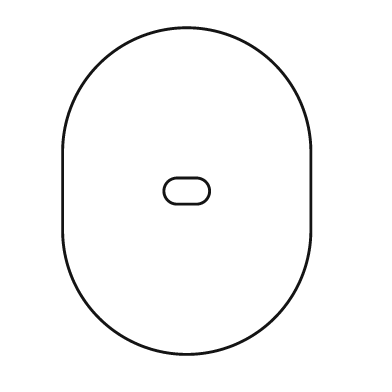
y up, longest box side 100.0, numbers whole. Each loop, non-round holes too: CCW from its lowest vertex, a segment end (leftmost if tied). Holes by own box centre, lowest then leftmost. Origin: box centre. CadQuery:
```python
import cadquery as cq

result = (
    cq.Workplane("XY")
    .moveTo(-38.0, -12.0)
    .threePointArc((0.0, -50.0), (38.0, -12.0))
    .lineTo(38.0, 12.0)
    .threePointArc((0.0, 50.0), (-38.0, 12.0))
    .close()
    .moveTo(-3.0, -4.0)
    .lineTo(3.0, -4.0)
    .threePointArc((7.0, 0.0), (3.0, 4.0))
    .lineTo(-3.0, 4.0)
    .threePointArc((-7.0, 0.0), (-3.0, -4.0))
    .close()
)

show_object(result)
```